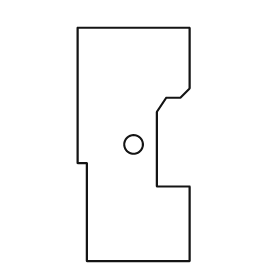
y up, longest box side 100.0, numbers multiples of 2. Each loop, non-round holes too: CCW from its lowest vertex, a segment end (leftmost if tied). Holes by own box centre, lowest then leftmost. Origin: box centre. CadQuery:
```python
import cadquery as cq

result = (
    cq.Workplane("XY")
    .moveTo(-20.0, -50.0)
    .lineTo(24.0, -50.0)
    .lineTo(24.0, -18.0)
    .lineTo(10.0, -18.0)
    .lineTo(10.0, 14.0)
    .lineTo(14.0, 20.0)
    .lineTo(20.0, 20.0)
    .lineTo(24.0, 24.0)
    .lineTo(24.0, 50.0)
    .lineTo(-24.0, 50.0)
    .lineTo(-24.0, -8.0)
    .lineTo(-20.0, -8.0)
    .close()
    .moveTo(0.0, 0.0)
    .circle(4.0)
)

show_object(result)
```